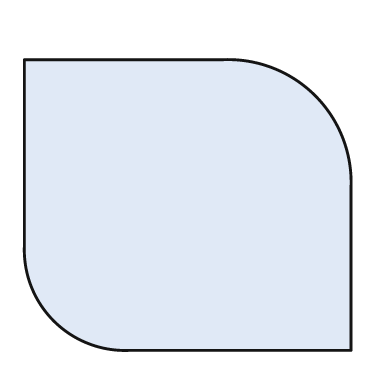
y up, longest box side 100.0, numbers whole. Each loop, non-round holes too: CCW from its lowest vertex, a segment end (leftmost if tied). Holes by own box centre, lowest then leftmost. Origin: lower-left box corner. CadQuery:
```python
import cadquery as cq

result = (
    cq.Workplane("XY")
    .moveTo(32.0, 0.0)
    .lineTo(100.0, 0.0)
    .lineTo(100.0, 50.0)
    .threePointArc((89.0, 78.0), (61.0, 89.0))
    .lineTo(0.0, 89.0)
    .lineTo(0.0, 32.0)
    .threePointArc((9.0, 9.0), (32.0, 0.0))
    .close()
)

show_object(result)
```